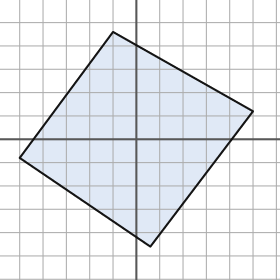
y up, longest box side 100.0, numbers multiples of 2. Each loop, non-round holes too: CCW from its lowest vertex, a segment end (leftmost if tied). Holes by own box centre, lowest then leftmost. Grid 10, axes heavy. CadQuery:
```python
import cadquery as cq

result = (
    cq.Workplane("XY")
    .moveTo(6.0, -46.0)
    .lineTo(50.0, 12.0)
    .lineTo(-10.0, 46.0)
    .lineTo(-50.0, -8.0)
    .close()
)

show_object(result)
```